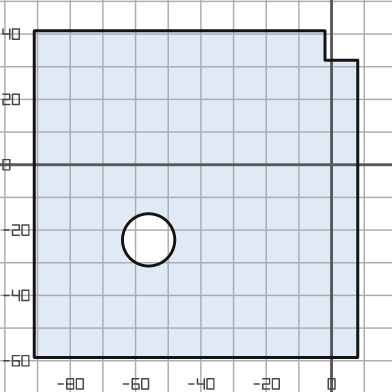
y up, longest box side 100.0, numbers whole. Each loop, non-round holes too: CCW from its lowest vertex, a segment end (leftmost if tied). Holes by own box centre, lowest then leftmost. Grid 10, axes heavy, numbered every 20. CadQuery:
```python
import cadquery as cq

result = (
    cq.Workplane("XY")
    .moveTo(-91.0, -59.0)
    .lineTo(8.0, -59.0)
    .lineTo(8.0, 32.0)
    .lineTo(-2.0, 32.0)
    .lineTo(-2.0, 41.0)
    .lineTo(-91.0, 41.0)
    .close()
    .moveTo(-56.0, -23.0)
    .circle(8.0)
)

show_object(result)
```